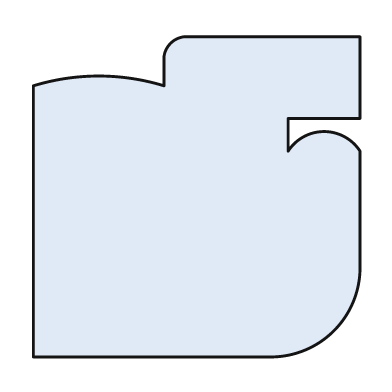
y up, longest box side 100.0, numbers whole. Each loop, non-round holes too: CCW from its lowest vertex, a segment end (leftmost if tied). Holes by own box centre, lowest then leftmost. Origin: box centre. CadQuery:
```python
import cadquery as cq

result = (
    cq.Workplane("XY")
    .moveTo(-50.0, -49.0)
    .lineTo(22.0, -49.0)
    .threePointArc((42.0, -41.0), (50.0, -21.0))
    .lineTo(50.0, 14.0)
    .threePointArc((39.0, 20.0), (28.0, 14.0))
    .lineTo(28.0, 24.0)
    .lineTo(50.0, 24.0)
    .lineTo(50.0, 49.0)
    .lineTo(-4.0, 49.0)
    .threePointArc((-8.0, 47.0), (-10.0, 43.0))
    .lineTo(-10.0, 34.0)
    .threePointArc((-30.0, 37.0), (-50.0, 34.0))
    .close()
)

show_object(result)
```